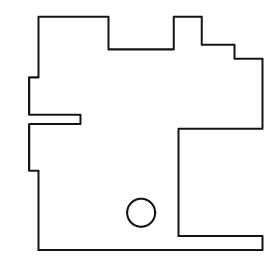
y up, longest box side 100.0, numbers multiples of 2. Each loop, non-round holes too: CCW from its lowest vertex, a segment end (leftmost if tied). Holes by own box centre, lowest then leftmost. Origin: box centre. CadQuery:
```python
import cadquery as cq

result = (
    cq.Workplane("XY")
    .moveTo(-46.0, -50.0)
    .lineTo(50.0, -50.0)
    .lineTo(50.0, -44.0)
    .lineTo(14.0, -44.0)
    .lineTo(14.0, 2.0)
    .lineTo(50.0, 2.0)
    .lineTo(50.0, 32.0)
    .lineTo(38.0, 32.0)
    .lineTo(38.0, 38.0)
    .lineTo(24.0, 38.0)
    .lineTo(24.0, 50.0)
    .lineTo(12.0, 50.0)
    .lineTo(12.0, 36.0)
    .lineTo(-16.0, 36.0)
    .lineTo(-16.0, 50.0)
    .lineTo(-46.0, 50.0)
    .lineTo(-46.0, 24.0)
    .lineTo(-50.0, 24.0)
    .lineTo(-50.0, 8.0)
    .lineTo(-28.0, 8.0)
    .lineTo(-28.0, 4.0)
    .lineTo(-50.0, 4.0)
    .lineTo(-50.0, -16.0)
    .lineTo(-46.0, -16.0)
    .close()
    .moveTo(-2.0, -34.0)
    .circle(6.0)
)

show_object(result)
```